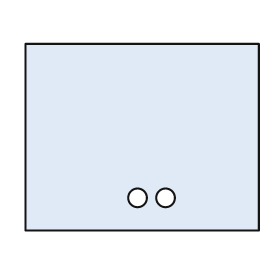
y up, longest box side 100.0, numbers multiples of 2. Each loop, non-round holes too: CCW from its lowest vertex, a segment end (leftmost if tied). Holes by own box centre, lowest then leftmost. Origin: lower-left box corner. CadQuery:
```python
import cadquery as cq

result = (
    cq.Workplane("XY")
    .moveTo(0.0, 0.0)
    .lineTo(100.0, 0.0)
    .lineTo(100.0, 80.0)
    .lineTo(0.0, 80.0)
    .close()
    .moveTo(48.0, 14.0)
    .circle(4.0)
    .moveTo(60.0, 14.0)
    .circle(4.0)
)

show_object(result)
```